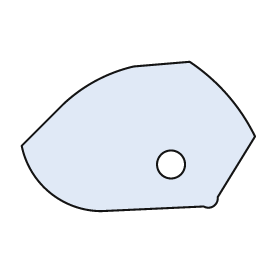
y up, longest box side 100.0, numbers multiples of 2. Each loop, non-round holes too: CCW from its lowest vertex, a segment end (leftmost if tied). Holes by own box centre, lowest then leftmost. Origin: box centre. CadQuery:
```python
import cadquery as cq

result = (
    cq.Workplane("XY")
    .moveTo(-16.0, -32.0)
    .lineTo(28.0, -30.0)
    .threePointArc((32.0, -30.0), (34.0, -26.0))
    .lineTo(50.0, 0.0)
    .threePointArc((38.0, 18.0), (22.0, 32.0))
    .lineTo(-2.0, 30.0)
    .threePointArc((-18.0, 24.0), (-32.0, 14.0))
    .lineTo(-50.0, -4.0)
    .threePointArc((-38.0, -24.0), (-16.0, -32.0))
    .close()
    .moveTo(14.0, -12.0)
    .circle(6.0)
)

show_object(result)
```